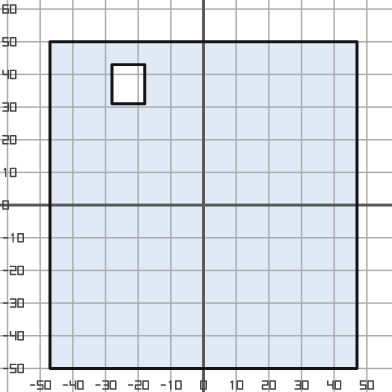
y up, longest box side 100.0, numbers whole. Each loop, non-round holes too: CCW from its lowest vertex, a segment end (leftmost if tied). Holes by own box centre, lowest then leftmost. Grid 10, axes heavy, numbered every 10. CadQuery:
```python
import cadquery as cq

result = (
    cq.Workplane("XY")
    .moveTo(-47.0, -50.0)
    .lineTo(47.0, -50.0)
    .lineTo(47.0, 50.0)
    .lineTo(-47.0, 50.0)
    .close()
    .moveTo(-28.0, 31.0)
    .lineTo(-18.0, 31.0)
    .lineTo(-18.0, 43.0)
    .lineTo(-28.0, 43.0)
    .close()
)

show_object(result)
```